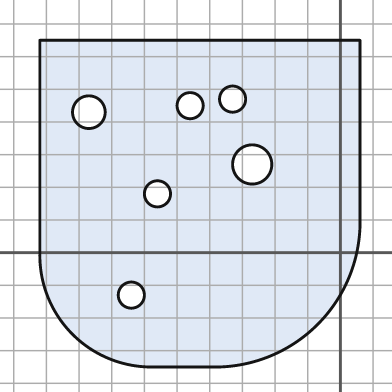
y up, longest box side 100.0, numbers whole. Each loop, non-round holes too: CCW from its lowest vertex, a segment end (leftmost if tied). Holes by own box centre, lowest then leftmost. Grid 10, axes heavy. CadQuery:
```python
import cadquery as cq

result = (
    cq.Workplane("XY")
    .moveTo(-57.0, -35.0)
    .lineTo(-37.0, -35.0)
    .threePointArc((-7.0, -22.0), (6.0, 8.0))
    .lineTo(6.0, 65.0)
    .lineTo(-92.0, 65.0)
    .lineTo(-92.0, 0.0)
    .threePointArc((-82.0, -25.0), (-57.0, -35.0))
    .close()
    .moveTo(-64.0, -13.0)
    .circle(4.0)
    .moveTo(-56.0, 18.0)
    .circle(4.0)
    .moveTo(-27.0, 27.0)
    .circle(6.0)
    .moveTo(-77.0, 43.0)
    .circle(5.0)
    .moveTo(-46.0, 45.0)
    .circle(4.0)
    .moveTo(-33.0, 47.0)
    .circle(4.0)
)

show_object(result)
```